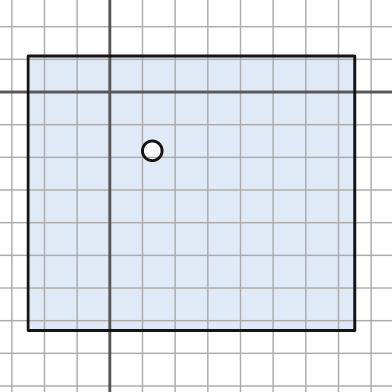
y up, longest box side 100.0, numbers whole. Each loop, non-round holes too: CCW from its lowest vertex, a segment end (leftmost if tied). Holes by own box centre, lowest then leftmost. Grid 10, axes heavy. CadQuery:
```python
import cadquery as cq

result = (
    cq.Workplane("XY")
    .moveTo(-25.0, -73.0)
    .lineTo(75.0, -73.0)
    .lineTo(75.0, 11.0)
    .lineTo(-25.0, 11.0)
    .close()
    .moveTo(13.0, -18.0)
    .circle(3.0)
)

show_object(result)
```